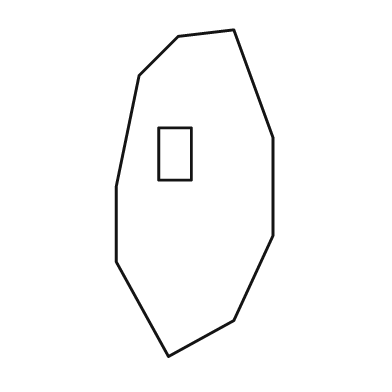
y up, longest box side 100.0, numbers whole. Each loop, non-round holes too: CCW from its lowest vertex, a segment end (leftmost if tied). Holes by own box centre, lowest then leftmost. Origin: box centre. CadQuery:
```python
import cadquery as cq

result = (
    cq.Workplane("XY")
    .moveTo(-8.0, -50.0)
    .lineTo(12.0, -39.0)
    .lineTo(24.0, -13.0)
    .lineTo(24.0, 17.0)
    .lineTo(12.0, 50.0)
    .lineTo(-5.0, 48.0)
    .lineTo(-17.0, 36.0)
    .lineTo(-24.0, 2.0)
    .lineTo(-24.0, -21.0)
    .close()
    .moveTo(-11.0, 4.0)
    .lineTo(-1.0, 4.0)
    .lineTo(-1.0, 20.0)
    .lineTo(-11.0, 20.0)
    .close()
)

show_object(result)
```